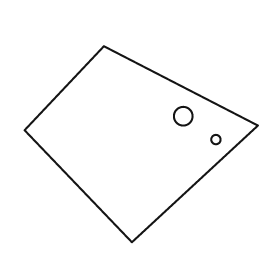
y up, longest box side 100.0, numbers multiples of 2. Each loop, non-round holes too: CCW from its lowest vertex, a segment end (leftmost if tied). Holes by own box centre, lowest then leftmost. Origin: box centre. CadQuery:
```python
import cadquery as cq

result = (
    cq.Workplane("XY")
    .moveTo(-4.0, -42.0)
    .lineTo(50.0, 8.0)
    .lineTo(-16.0, 42.0)
    .lineTo(-50.0, 6.0)
    .close()
    .moveTo(32.0, 2.0)
    .circle(2.0)
    .moveTo(18.0, 12.0)
    .circle(4.0)
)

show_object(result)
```